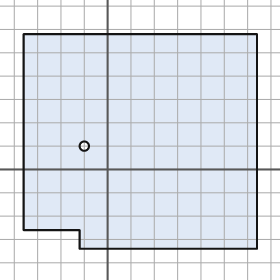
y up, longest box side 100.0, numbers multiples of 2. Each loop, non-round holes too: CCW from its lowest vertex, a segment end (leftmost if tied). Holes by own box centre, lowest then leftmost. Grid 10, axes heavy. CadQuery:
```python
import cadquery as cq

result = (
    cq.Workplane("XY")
    .moveTo(-12.0, -34.0)
    .lineTo(64.0, -34.0)
    .lineTo(64.0, 58.0)
    .lineTo(-36.0, 58.0)
    .lineTo(-36.0, -26.0)
    .lineTo(-12.0, -26.0)
    .close()
    .moveTo(-10.0, 10.0)
    .circle(2.0)
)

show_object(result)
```